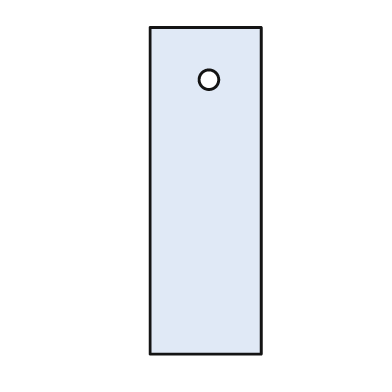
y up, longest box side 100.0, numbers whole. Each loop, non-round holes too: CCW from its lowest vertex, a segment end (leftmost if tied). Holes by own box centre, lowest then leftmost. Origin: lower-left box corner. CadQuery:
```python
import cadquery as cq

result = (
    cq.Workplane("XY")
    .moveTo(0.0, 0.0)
    .lineTo(34.0, 0.0)
    .lineTo(34.0, 100.0)
    .lineTo(0.0, 100.0)
    .close()
    .moveTo(18.0, 84.0)
    .circle(3.0)
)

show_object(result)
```